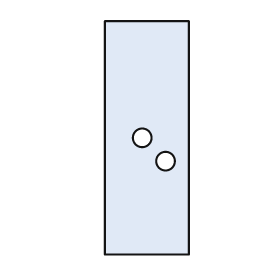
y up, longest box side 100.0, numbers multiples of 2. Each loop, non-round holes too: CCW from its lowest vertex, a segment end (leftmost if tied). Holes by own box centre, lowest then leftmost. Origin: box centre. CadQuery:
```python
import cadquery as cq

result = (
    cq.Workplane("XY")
    .moveTo(-18.0, -50.0)
    .lineTo(18.0, -50.0)
    .lineTo(18.0, 50.0)
    .lineTo(-18.0, 50.0)
    .close()
    .moveTo(8.0, -10.0)
    .circle(4.0)
    .moveTo(-2.0, 0.0)
    .circle(4.0)
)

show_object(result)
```